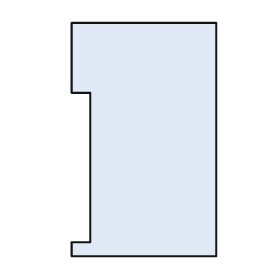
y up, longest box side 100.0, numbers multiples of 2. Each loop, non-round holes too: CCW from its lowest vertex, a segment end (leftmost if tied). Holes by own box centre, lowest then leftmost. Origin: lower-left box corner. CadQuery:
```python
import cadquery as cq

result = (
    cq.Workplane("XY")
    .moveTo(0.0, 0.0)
    .lineTo(62.0, 0.0)
    .lineTo(62.0, 100.0)
    .lineTo(0.0, 100.0)
    .lineTo(0.0, 70.0)
    .lineTo(8.0, 70.0)
    .lineTo(8.0, 6.0)
    .lineTo(0.0, 6.0)
    .close()
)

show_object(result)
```